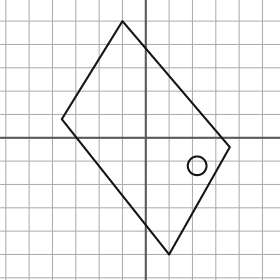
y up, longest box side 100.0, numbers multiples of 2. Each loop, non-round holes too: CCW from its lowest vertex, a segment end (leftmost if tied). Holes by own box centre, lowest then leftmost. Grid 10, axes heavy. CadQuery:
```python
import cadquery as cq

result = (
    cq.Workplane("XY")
    .moveTo(10.0, -50.0)
    .lineTo(36.0, -4.0)
    .lineTo(-10.0, 50.0)
    .lineTo(-36.0, 8.0)
    .close()
    .moveTo(22.0, -12.0)
    .circle(4.0)
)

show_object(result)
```